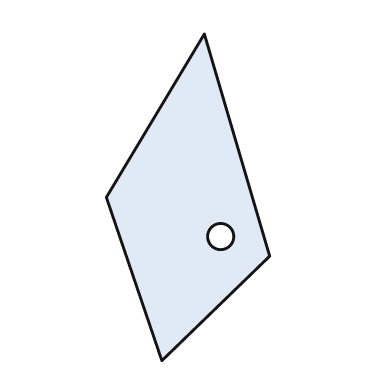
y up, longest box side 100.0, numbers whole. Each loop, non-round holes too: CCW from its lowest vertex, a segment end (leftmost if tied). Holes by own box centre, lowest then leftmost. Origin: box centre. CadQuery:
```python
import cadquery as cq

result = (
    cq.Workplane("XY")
    .moveTo(-8.0, -50.0)
    .lineTo(25.0, -18.0)
    .lineTo(5.0, 50.0)
    .lineTo(-25.0, 0.0)
    .close()
    .moveTo(10.0, -12.0)
    .circle(4.0)
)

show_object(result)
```